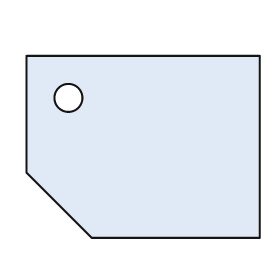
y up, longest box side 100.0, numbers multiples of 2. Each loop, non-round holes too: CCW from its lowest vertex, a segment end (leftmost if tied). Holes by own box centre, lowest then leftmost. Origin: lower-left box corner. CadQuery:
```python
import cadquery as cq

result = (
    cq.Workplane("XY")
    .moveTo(28.0, 0.0)
    .lineTo(100.0, 0.0)
    .lineTo(100.0, 78.0)
    .lineTo(0.0, 78.0)
    .lineTo(0.0, 28.0)
    .close()
    .moveTo(18.0, 60.0)
    .circle(6.0)
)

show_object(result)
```